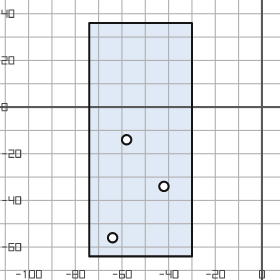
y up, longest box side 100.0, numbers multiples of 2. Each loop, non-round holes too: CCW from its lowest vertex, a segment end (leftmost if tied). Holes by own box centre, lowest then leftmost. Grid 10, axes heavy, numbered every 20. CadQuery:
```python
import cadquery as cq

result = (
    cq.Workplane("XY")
    .moveTo(-74.0, -64.0)
    .lineTo(-30.0, -64.0)
    .lineTo(-30.0, 36.0)
    .lineTo(-74.0, 36.0)
    .close()
    .moveTo(-64.0, -56.0)
    .circle(2.0)
    .moveTo(-42.0, -34.0)
    .circle(2.0)
    .moveTo(-58.0, -14.0)
    .circle(2.0)
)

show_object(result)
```